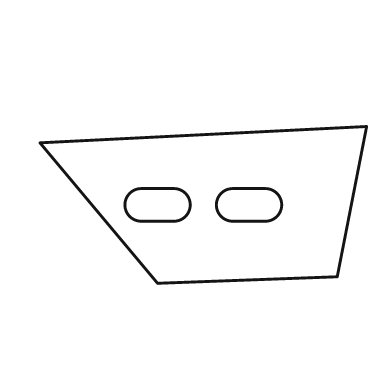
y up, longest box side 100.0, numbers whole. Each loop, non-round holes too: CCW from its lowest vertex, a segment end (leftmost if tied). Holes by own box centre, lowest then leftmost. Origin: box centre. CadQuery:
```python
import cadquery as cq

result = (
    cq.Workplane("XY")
    .moveTo(-14.0, -24.0)
    .lineTo(41.0, -22.0)
    .lineTo(50.0, 24.0)
    .lineTo(-50.0, 19.0)
    .close()
    .moveTo(-19.0, -5.0)
    .lineTo(-9.0, -5.0)
    .threePointArc((-4.0, 0.0), (-9.0, 5.0))
    .lineTo(-19.0, 5.0)
    .threePointArc((-24.0, 0.0), (-19.0, -5.0))
    .close()
    .moveTo(9.0, -5.0)
    .lineTo(19.0, -5.0)
    .threePointArc((24.0, 0.0), (19.0, 5.0))
    .lineTo(9.0, 5.0)
    .threePointArc((4.0, 0.0), (9.0, -5.0))
    .close()
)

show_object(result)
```